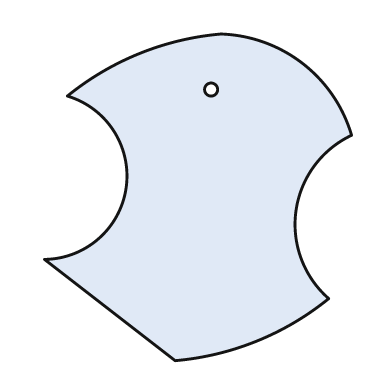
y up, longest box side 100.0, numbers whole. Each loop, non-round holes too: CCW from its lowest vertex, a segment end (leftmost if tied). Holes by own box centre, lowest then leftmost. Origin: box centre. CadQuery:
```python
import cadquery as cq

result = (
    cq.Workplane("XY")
    .moveTo(-7.0, -50.0)
    .threePointArc((18.0, -44.0), (40.0, -31.0))
    .threePointArc((30.0, -4.0), (47.0, 19.0))
    .threePointArc((32.0, 41.0), (7.0, 50.0))
    .threePointArc((-18.0, 44.0), (-40.0, 31.0))
    .threePointArc((-22.0, 3.0), (-47.0, -19.0))
    .close()
    .moveTo(4.0, 33.0)
    .circle(2.0)
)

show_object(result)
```